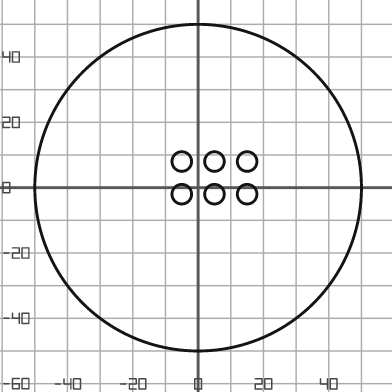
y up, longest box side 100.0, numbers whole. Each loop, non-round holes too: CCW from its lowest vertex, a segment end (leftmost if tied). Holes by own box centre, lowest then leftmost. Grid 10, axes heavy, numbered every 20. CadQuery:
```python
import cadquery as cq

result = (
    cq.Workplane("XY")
    .moveTo(0.0, 0.0)
    .circle(50.0)
    .moveTo(-5.0, -2.0)
    .circle(3.0)
    .moveTo(5.0, -2.0)
    .circle(3.0)
    .moveTo(15.0, -2.0)
    .circle(3.0)
    .moveTo(-5.0, 8.0)
    .circle(3.0)
    .moveTo(5.0, 8.0)
    .circle(3.0)
    .moveTo(15.0, 8.0)
    .circle(3.0)
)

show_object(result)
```